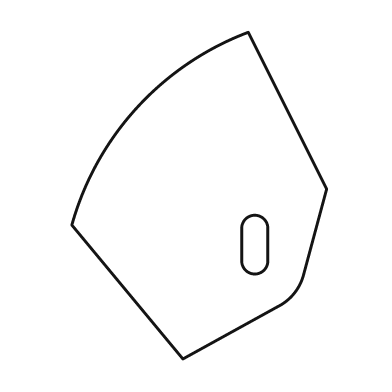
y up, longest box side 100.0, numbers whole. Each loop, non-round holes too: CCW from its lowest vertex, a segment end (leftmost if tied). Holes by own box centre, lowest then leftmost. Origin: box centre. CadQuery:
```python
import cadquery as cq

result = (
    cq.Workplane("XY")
    .moveTo(-5.0, -50.0)
    .lineTo(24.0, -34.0)
    .threePointArc((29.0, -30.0), (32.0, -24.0))
    .lineTo(39.0, 2.0)
    .lineTo(15.0, 50.0)
    .threePointArc((-19.0, 27.0), (-39.0, -9.0))
    .close()
    .moveTo(13.0, -20.0)
    .threePointArc((17.0, -24.0), (21.0, -20.0))
    .lineTo(21.0, -10.0)
    .threePointArc((17.0, -6.0), (13.0, -10.0))
    .close()
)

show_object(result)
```